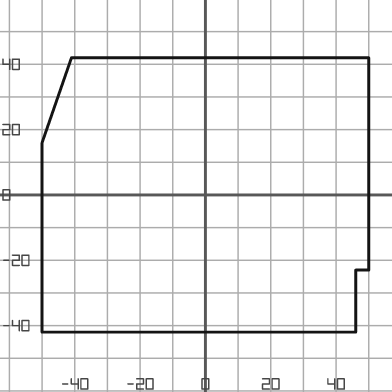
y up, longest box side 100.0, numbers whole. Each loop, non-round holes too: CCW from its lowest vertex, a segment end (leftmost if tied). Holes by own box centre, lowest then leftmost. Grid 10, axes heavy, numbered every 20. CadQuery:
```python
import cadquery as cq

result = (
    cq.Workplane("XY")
    .moveTo(-50.0, -42.0)
    .lineTo(46.0, -42.0)
    .lineTo(46.0, -23.0)
    .lineTo(50.0, -23.0)
    .lineTo(50.0, 42.0)
    .lineTo(-41.0, 42.0)
    .lineTo(-50.0, 16.0)
    .close()
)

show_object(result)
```